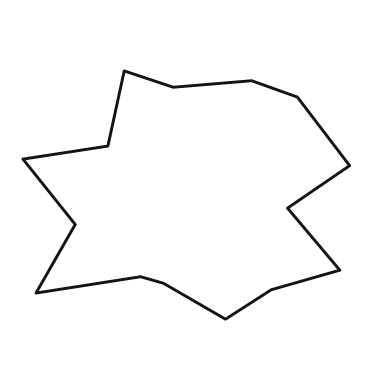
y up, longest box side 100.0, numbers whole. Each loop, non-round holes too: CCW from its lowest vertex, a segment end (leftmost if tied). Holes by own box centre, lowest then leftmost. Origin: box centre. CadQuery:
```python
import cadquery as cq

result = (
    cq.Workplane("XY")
    .moveTo(12.0, -38.0)
    .lineTo(26.0, -29.0)
    .lineTo(47.0, -23.0)
    .lineTo(31.0, -4.0)
    .lineTo(50.0, 9.0)
    .lineTo(34.0, 30.0)
    .lineTo(20.0, 35.0)
    .lineTo(-4.0, 33.0)
    .lineTo(-19.0, 38.0)
    .lineTo(-24.0, 15.0)
    .lineTo(-50.0, 11.0)
    .lineTo(-34.0, -9.0)
    .lineTo(-46.0, -30.0)
    .lineTo(-14.0, -25.0)
    .lineTo(-7.0, -27.0)
    .close()
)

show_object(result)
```